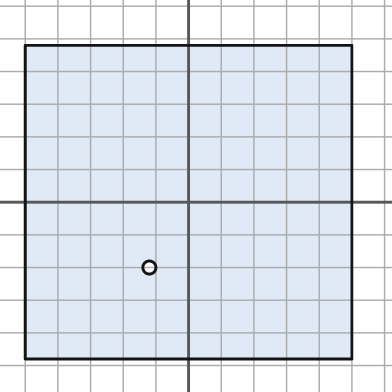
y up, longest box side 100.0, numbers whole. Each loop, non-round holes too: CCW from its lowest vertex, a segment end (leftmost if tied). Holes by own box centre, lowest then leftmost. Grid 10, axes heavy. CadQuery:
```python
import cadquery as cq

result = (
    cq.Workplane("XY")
    .moveTo(-50.0, -48.0)
    .lineTo(50.0, -48.0)
    .lineTo(50.0, 48.0)
    .lineTo(-50.0, 48.0)
    .close()
    .moveTo(-12.0, -20.0)
    .circle(2.0)
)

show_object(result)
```